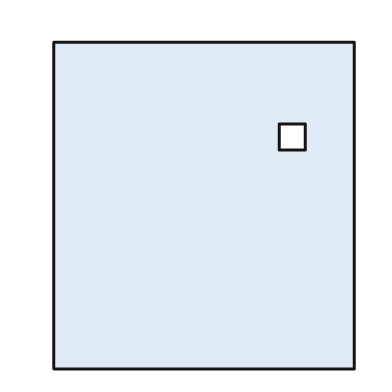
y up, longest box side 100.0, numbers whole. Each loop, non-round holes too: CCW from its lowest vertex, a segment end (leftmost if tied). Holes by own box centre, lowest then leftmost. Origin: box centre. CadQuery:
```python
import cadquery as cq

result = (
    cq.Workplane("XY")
    .moveTo(-46.0, -50.0)
    .lineTo(46.0, -50.0)
    .lineTo(46.0, 50.0)
    .lineTo(-46.0, 50.0)
    .close()
    .moveTo(23.0, 17.0)
    .lineTo(31.0, 17.0)
    .lineTo(31.0, 25.0)
    .lineTo(23.0, 25.0)
    .close()
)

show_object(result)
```